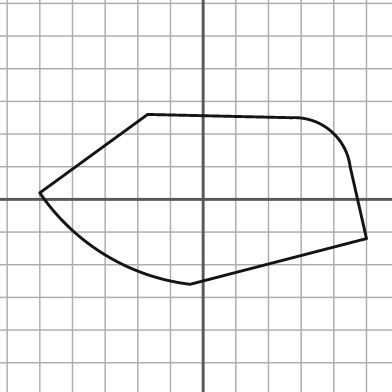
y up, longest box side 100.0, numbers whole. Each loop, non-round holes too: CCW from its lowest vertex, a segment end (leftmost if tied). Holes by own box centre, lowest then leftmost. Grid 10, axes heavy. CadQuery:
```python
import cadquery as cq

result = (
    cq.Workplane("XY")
    .moveTo(-4.0, -26.0)
    .lineTo(50.0, -12.0)
    .lineTo(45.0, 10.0)
    .threePointArc((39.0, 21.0), (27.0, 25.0))
    .lineTo(-17.0, 26.0)
    .lineTo(-50.0, 2.0)
    .threePointArc((-30.0, -17.0), (-4.0, -26.0))
    .close()
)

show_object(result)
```